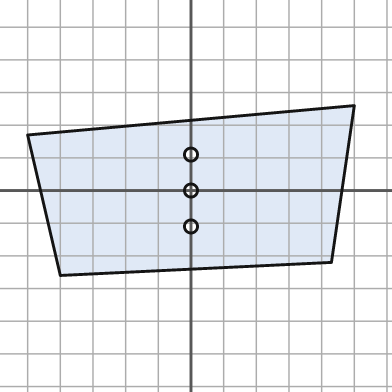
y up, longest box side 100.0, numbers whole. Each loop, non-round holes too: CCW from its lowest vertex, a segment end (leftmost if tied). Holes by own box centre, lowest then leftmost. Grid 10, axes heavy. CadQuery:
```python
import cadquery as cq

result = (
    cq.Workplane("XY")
    .moveTo(-40.0, -26.0)
    .lineTo(43.0, -22.0)
    .lineTo(50.0, 26.0)
    .lineTo(-50.0, 17.0)
    .close()
    .moveTo(0.0, -11.0)
    .circle(2.0)
    .moveTo(0.0, 0.0)
    .circle(2.0)
    .moveTo(0.0, 11.0)
    .circle(2.0)
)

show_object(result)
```